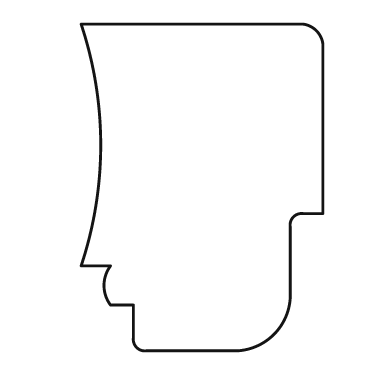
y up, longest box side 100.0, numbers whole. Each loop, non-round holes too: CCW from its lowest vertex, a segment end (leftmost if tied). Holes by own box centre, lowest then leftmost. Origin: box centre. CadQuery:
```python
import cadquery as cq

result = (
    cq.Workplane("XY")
    .moveTo(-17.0, -50.0)
    .lineTo(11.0, -50.0)
    .threePointArc((22.0, -45.0), (27.0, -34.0))
    .lineTo(27.0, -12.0)
    .threePointArc((28.0, -9.0), (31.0, -8.0))
    .lineTo(37.0, -8.0)
    .lineTo(37.0, 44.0)
    .threePointArc((35.0, 48.0), (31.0, 50.0))
    .lineTo(-37.0, 50.0)
    .threePointArc((-31.0, 13.0), (-37.0, -24.0))
    .lineTo(-28.0, -24.0)
    .threePointArc((-30.0, -30.0), (-28.0, -36.0))
    .lineTo(-21.0, -36.0)
    .lineTo(-21.0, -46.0)
    .threePointArc((-20.0, -49.0), (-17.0, -50.0))
    .close()
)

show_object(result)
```